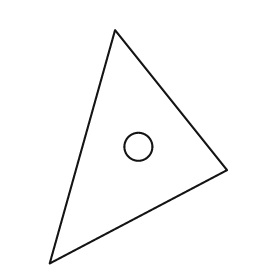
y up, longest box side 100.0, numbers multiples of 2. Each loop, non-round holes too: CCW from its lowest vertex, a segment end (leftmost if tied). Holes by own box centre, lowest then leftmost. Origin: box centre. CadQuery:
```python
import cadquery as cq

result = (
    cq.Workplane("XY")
    .moveTo(-38.0, -50.0)
    .lineTo(38.0, -10.0)
    .lineTo(-10.0, 50.0)
    .close()
    .moveTo(0.0, 0.0)
    .circle(6.0)
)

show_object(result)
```